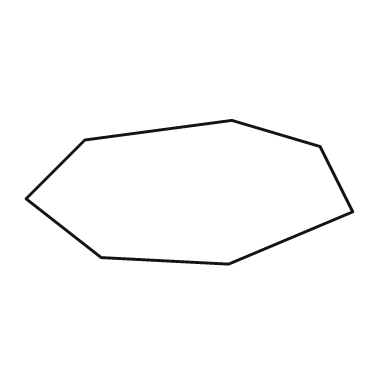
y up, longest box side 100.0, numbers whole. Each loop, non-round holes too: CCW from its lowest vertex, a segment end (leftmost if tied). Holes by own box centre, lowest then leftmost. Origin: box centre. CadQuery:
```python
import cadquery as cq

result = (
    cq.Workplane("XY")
    .moveTo(12.0, -22.0)
    .lineTo(50.0, -6.0)
    .lineTo(40.0, 14.0)
    .lineTo(13.0, 22.0)
    .lineTo(-32.0, 16.0)
    .lineTo(-50.0, -2.0)
    .lineTo(-27.0, -20.0)
    .close()
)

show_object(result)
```